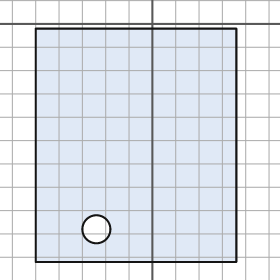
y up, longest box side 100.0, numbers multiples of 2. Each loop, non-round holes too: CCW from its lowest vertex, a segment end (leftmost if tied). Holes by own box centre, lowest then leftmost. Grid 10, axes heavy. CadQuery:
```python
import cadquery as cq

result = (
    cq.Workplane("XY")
    .moveTo(-50.0, -102.0)
    .lineTo(36.0, -102.0)
    .lineTo(36.0, -2.0)
    .lineTo(-50.0, -2.0)
    .close()
    .moveTo(-24.0, -88.0)
    .circle(6.0)
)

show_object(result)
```